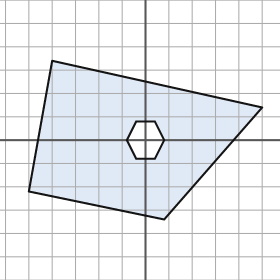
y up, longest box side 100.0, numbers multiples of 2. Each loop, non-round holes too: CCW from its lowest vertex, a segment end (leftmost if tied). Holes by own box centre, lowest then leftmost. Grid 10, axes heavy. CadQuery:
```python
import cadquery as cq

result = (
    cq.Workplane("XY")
    .moveTo(8.0, -34.0)
    .lineTo(50.0, 14.0)
    .lineTo(-40.0, 34.0)
    .lineTo(-50.0, -22.0)
    .close()
    .moveTo(-4.0, -8.0)
    .lineTo(4.0, -8.0)
    .lineTo(8.0, 0.0)
    .lineTo(4.0, 8.0)
    .lineTo(-4.0, 8.0)
    .lineTo(-8.0, 0.0)
    .close()
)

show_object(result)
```